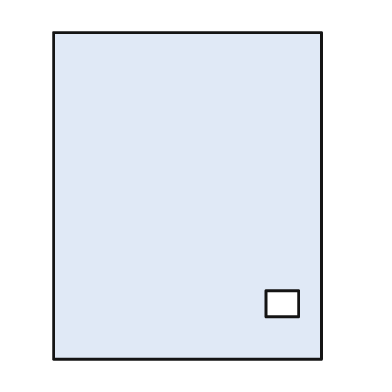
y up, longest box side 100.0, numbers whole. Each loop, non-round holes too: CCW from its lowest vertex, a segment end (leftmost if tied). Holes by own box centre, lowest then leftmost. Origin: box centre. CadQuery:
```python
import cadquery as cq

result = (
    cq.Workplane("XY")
    .moveTo(-41.0, -50.0)
    .lineTo(41.0, -50.0)
    .lineTo(41.0, 50.0)
    .lineTo(-41.0, 50.0)
    .close()
    .moveTo(24.0, -37.0)
    .lineTo(34.0, -37.0)
    .lineTo(34.0, -29.0)
    .lineTo(24.0, -29.0)
    .close()
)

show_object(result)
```